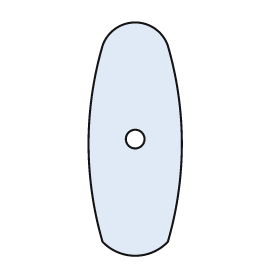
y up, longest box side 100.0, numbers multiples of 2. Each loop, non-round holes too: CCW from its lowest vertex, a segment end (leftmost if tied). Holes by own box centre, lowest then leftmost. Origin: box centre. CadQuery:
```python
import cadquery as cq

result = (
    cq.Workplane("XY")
    .moveTo(-14.0, -44.0)
    .threePointArc((0.0, -50.0), (14.0, -44.0))
    .threePointArc((20.0, -2.0), (14.0, 40.0))
    .threePointArc((0.0, 50.0), (-14.0, 40.0))
    .threePointArc((-20.0, -2.0), (-14.0, -44.0))
    .close()
    .moveTo(0.0, 0.0)
    .circle(4.0)
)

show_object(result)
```